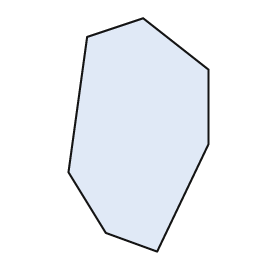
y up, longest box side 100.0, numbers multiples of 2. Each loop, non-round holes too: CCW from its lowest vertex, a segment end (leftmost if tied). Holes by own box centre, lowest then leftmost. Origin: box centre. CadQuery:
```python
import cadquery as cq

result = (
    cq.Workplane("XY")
    .moveTo(8.0, -50.0)
    .lineTo(30.0, -4.0)
    .lineTo(30.0, 28.0)
    .lineTo(2.0, 50.0)
    .lineTo(-22.0, 42.0)
    .lineTo(-30.0, -16.0)
    .lineTo(-14.0, -42.0)
    .close()
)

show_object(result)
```